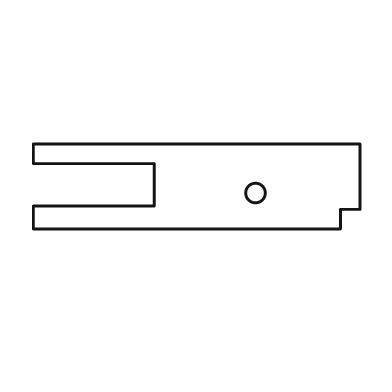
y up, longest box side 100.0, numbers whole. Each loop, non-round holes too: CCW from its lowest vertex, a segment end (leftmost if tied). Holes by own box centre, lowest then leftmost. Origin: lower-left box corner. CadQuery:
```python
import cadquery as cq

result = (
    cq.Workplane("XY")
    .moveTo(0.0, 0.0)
    .lineTo(94.0, 0.0)
    .lineTo(94.0, 6.0)
    .lineTo(100.0, 6.0)
    .lineTo(100.0, 26.0)
    .lineTo(0.0, 26.0)
    .lineTo(0.0, 20.0)
    .lineTo(37.0, 20.0)
    .lineTo(37.0, 7.0)
    .lineTo(0.0, 7.0)
    .close()
    .moveTo(68.0, 11.0)
    .circle(3.0)
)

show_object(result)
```